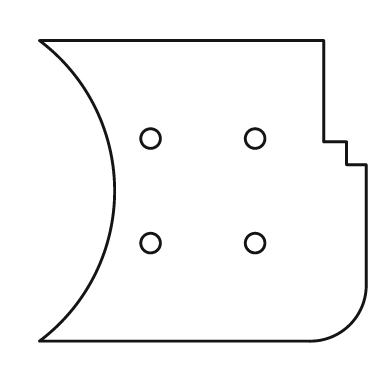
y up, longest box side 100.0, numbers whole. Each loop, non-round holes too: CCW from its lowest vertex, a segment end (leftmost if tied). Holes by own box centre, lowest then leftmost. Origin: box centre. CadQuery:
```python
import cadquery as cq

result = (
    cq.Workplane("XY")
    .moveTo(-50.0, -46.0)
    .lineTo(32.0, -46.0)
    .threePointArc((45.0, -41.0), (50.0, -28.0))
    .lineTo(50.0, 8.0)
    .lineTo(44.0, 8.0)
    .lineTo(44.0, 15.0)
    .lineTo(37.0, 15.0)
    .lineTo(37.0, 46.0)
    .lineTo(-50.0, 46.0)
    .threePointArc((-27.0, 0.0), (-50.0, -46.0))
    .close()
    .moveTo(-16.0, -16.0)
    .circle(3.0)
    .moveTo(16.0, -16.0)
    .circle(3.0)
    .moveTo(-16.0, 16.0)
    .circle(3.0)
    .moveTo(16.0, 16.0)
    .circle(3.0)
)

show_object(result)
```